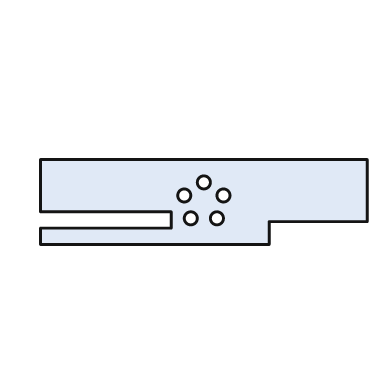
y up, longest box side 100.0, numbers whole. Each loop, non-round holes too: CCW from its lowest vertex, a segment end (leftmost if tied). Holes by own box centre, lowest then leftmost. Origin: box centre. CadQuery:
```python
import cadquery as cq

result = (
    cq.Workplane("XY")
    .moveTo(-50.0, -13.0)
    .lineTo(20.0, -13.0)
    .lineTo(20.0, -6.0)
    .lineTo(50.0, -6.0)
    .lineTo(50.0, 13.0)
    .lineTo(-50.0, 13.0)
    .lineTo(-50.0, -3.0)
    .lineTo(-10.0, -3.0)
    .lineTo(-10.0, -8.0)
    .lineTo(-50.0, -8.0)
    .close()
    .moveTo(-4.0, -5.0)
    .circle(2.0)
    .moveTo(4.0, -5.0)
    .circle(2.0)
    .moveTo(-6.0, 2.0)
    .circle(2.0)
    .moveTo(6.0, 2.0)
    .circle(2.0)
    .moveTo(0.0, 6.0)
    .circle(2.0)
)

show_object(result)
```